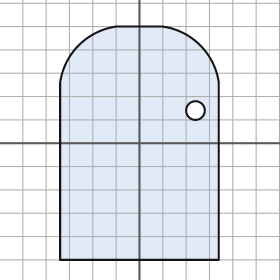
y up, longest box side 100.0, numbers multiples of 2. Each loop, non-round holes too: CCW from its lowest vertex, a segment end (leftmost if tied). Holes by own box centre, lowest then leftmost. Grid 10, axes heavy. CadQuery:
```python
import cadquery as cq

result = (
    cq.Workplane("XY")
    .moveTo(-34.0, -50.0)
    .lineTo(34.0, -50.0)
    .lineTo(34.0, 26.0)
    .threePointArc((26.0, 42.0), (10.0, 50.0))
    .lineTo(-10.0, 50.0)
    .threePointArc((-26.0, 42.0), (-34.0, 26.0))
    .close()
    .moveTo(24.0, 14.0)
    .circle(4.0)
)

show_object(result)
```